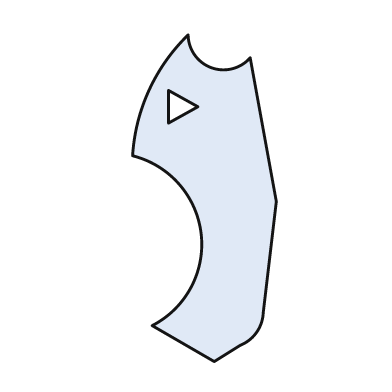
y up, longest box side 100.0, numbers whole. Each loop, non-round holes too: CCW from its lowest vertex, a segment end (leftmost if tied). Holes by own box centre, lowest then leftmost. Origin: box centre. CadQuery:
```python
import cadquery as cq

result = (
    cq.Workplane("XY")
    .moveTo(3.0, -50.0)
    .lineTo(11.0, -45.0)
    .threePointArc((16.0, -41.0), (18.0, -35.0))
    .lineTo(22.0, -1.0)
    .lineTo(14.0, 43.0)
    .threePointArc((2.0, 40.0), (-5.0, 50.0))
    .threePointArc((-17.0, 33.0), (-22.0, 13.0))
    .threePointArc((-1.0, -11.0), (-16.0, -39.0))
    .close()
    .moveTo(-11.0, 23.0)
    .lineTo(-2.0, 28.0)
    .lineTo(-11.0, 33.0)
    .close()
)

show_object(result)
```